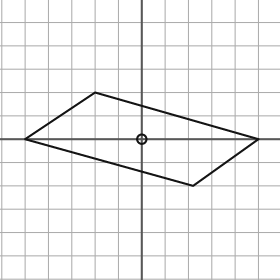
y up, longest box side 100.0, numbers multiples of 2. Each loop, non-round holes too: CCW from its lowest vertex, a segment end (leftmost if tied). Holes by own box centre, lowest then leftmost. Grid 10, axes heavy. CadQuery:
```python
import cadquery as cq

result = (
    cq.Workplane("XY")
    .moveTo(22.0, -20.0)
    .lineTo(50.0, 0.0)
    .lineTo(-20.0, 20.0)
    .lineTo(-50.0, 0.0)
    .close()
    .moveTo(0.0, 0.0)
    .circle(2.0)
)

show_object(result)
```